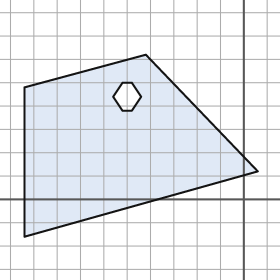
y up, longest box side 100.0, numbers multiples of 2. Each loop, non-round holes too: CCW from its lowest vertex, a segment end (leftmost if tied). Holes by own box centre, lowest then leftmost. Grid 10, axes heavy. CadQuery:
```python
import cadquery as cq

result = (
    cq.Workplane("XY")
    .moveTo(-94.0, -16.0)
    .lineTo(6.0, 12.0)
    .lineTo(-42.0, 62.0)
    .lineTo(-94.0, 48.0)
    .close()
    .moveTo(-52.0, 38.0)
    .lineTo(-48.0, 38.0)
    .lineTo(-44.0, 44.0)
    .lineTo(-48.0, 50.0)
    .lineTo(-52.0, 50.0)
    .lineTo(-56.0, 44.0)
    .close()
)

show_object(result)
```